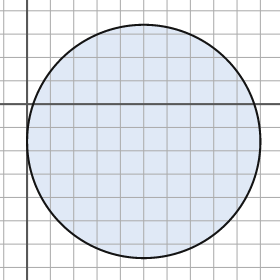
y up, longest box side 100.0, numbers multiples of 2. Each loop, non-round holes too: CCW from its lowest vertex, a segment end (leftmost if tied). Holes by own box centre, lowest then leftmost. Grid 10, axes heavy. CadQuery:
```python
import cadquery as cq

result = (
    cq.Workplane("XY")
    .moveTo(50.0, -16.0)
    .circle(50.0)
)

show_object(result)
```